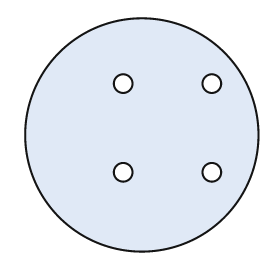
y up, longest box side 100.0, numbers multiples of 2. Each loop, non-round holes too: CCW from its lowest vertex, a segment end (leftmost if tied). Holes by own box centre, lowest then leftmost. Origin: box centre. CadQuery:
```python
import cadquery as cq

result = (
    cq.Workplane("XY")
    .moveTo(0.0, 0.0)
    .circle(50.0)
    .moveTo(-8.0, -16.0)
    .circle(4.0)
    .moveTo(30.0, -16.0)
    .circle(4.0)
    .moveTo(-8.0, 22.0)
    .circle(4.0)
    .moveTo(30.0, 22.0)
    .circle(4.0)
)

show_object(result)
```